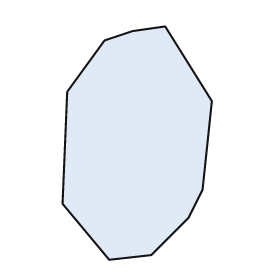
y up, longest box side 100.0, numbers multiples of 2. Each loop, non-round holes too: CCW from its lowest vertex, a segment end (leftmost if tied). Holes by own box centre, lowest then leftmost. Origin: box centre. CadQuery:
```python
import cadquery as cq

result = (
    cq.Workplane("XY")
    .moveTo(-12.0, -50.0)
    .lineTo(6.0, -48.0)
    .lineTo(22.0, -32.0)
    .lineTo(28.0, -20.0)
    .lineTo(32.0, 18.0)
    .lineTo(12.0, 50.0)
    .lineTo(-2.0, 48.0)
    .lineTo(-14.0, 44.0)
    .lineTo(-30.0, 22.0)
    .lineTo(-32.0, -26.0)
    .close()
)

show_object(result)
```